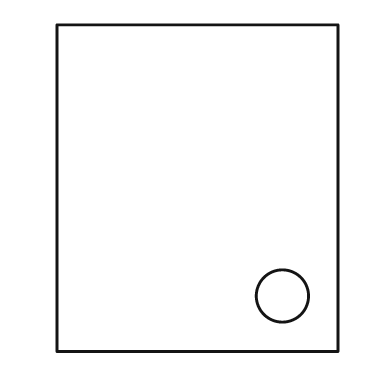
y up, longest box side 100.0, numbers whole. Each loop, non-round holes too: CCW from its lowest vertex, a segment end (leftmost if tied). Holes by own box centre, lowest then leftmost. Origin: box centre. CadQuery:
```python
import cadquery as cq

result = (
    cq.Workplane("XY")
    .moveTo(-43.0, -50.0)
    .lineTo(43.0, -50.0)
    .lineTo(43.0, 50.0)
    .lineTo(-43.0, 50.0)
    .close()
    .moveTo(26.0, -33.0)
    .circle(8.0)
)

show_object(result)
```